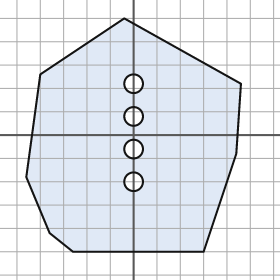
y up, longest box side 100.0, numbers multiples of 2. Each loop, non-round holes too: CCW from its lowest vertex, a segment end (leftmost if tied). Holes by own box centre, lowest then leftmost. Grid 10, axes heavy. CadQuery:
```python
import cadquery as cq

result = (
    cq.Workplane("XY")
    .moveTo(-26.0, -50.0)
    .lineTo(30.0, -50.0)
    .lineTo(44.0, -8.0)
    .lineTo(46.0, 22.0)
    .lineTo(-4.0, 50.0)
    .lineTo(-40.0, 26.0)
    .lineTo(-46.0, -18.0)
    .lineTo(-36.0, -42.0)
    .close()
    .moveTo(0.0, -20.0)
    .circle(4.0)
    .moveTo(0.0, -6.0)
    .circle(4.0)
    .moveTo(0.0, 8.0)
    .circle(4.0)
    .moveTo(0.0, 22.0)
    .circle(4.0)
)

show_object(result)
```